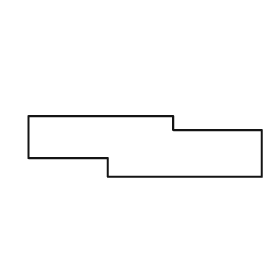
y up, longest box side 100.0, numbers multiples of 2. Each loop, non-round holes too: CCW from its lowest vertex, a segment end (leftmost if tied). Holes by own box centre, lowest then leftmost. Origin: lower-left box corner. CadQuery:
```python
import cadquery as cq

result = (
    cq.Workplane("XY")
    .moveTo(34.0, 0.0)
    .lineTo(100.0, 0.0)
    .lineTo(100.0, 20.0)
    .lineTo(62.0, 20.0)
    .lineTo(62.0, 26.0)
    .lineTo(0.0, 26.0)
    .lineTo(0.0, 8.0)
    .lineTo(34.0, 8.0)
    .close()
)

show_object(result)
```